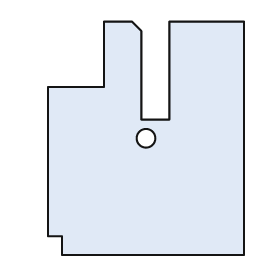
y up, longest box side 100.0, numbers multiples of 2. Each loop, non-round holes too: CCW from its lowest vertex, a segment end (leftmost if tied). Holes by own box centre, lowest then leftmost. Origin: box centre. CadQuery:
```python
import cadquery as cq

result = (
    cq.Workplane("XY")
    .moveTo(-36.0, -50.0)
    .lineTo(42.0, -50.0)
    .lineTo(42.0, 50.0)
    .lineTo(10.0, 50.0)
    .lineTo(10.0, 8.0)
    .lineTo(-2.0, 8.0)
    .lineTo(-2.0, 46.0)
    .lineTo(-6.0, 50.0)
    .lineTo(-18.0, 50.0)
    .lineTo(-18.0, 22.0)
    .lineTo(-42.0, 22.0)
    .lineTo(-42.0, -42.0)
    .lineTo(-36.0, -42.0)
    .close()
    .moveTo(0.0, 0.0)
    .circle(4.0)
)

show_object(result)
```